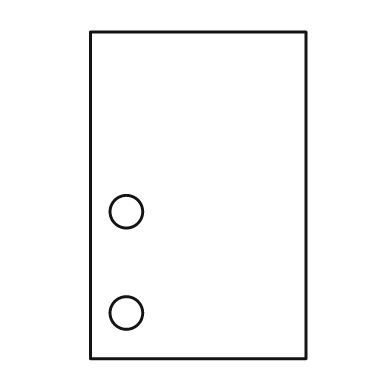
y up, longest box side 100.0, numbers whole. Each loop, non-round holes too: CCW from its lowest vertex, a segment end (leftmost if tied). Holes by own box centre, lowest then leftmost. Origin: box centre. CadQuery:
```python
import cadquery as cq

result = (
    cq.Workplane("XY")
    .moveTo(-33.0, -50.0)
    .lineTo(33.0, -50.0)
    .lineTo(33.0, 50.0)
    .lineTo(-33.0, 50.0)
    .close()
    .moveTo(-22.0, -36.0)
    .circle(5.0)
    .moveTo(-22.0, -5.0)
    .circle(5.0)
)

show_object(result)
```